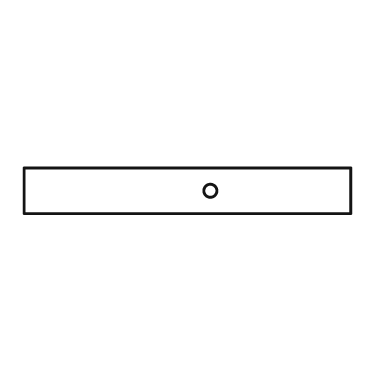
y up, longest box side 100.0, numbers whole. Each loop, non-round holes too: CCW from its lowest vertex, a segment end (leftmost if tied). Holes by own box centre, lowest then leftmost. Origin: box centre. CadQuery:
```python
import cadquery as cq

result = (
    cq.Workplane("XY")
    .moveTo(-50.0, -7.0)
    .lineTo(50.0, -7.0)
    .lineTo(50.0, 7.0)
    .lineTo(-50.0, 7.0)
    .close()
    .moveTo(7.0, 0.0)
    .circle(2.0)
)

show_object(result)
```